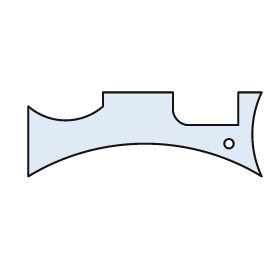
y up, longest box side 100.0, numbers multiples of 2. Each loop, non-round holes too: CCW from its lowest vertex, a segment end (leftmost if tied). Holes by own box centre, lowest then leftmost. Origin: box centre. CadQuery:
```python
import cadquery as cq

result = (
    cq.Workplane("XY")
    .moveTo(-50.0, -18.0)
    .threePointArc((0.0, -4.0), (50.0, -18.0))
    .threePointArc((46.0, 0.0), (50.0, 18.0))
    .lineTo(40.0, 18.0)
    .lineTo(40.0, 4.0)
    .lineTo(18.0, 4.0)
    .threePointArc((14.0, 6.0), (12.0, 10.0))
    .lineTo(12.0, 18.0)
    .lineTo(-18.0, 18.0)
    .lineTo(-18.0, 12.0)
    .threePointArc((-34.0, 6.0), (-50.0, 12.0))
    .close()
    .moveTo(36.0, -4.0)
    .circle(2.0)
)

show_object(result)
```